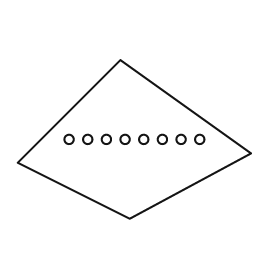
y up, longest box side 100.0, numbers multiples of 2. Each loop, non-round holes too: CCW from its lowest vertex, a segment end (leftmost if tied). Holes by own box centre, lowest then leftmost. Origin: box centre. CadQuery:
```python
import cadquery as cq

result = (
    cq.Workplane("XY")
    .moveTo(-2.0, -34.0)
    .lineTo(50.0, -6.0)
    .lineTo(-6.0, 34.0)
    .lineTo(-50.0, -10.0)
    .close()
    .moveTo(-28.0, 0.0)
    .circle(2.0)
    .moveTo(-20.0, 0.0)
    .circle(2.0)
    .moveTo(-12.0, 0.0)
    .circle(2.0)
    .moveTo(-4.0, 0.0)
    .circle(2.0)
    .moveTo(4.0, 0.0)
    .circle(2.0)
    .moveTo(12.0, 0.0)
    .circle(2.0)
    .moveTo(20.0, 0.0)
    .circle(2.0)
    .moveTo(28.0, 0.0)
    .circle(2.0)
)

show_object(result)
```